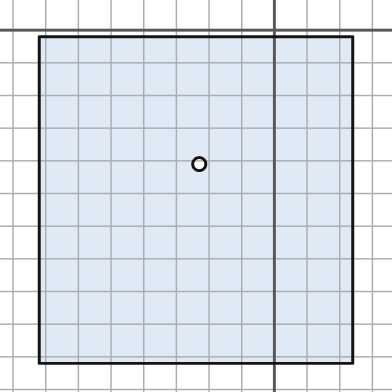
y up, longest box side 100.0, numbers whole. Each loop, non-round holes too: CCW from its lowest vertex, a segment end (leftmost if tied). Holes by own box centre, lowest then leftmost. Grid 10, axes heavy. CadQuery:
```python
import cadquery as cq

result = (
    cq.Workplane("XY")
    .moveTo(-72.0, -102.0)
    .lineTo(24.0, -102.0)
    .lineTo(24.0, -2.0)
    .lineTo(-72.0, -2.0)
    .close()
    .moveTo(-23.0, -41.0)
    .circle(2.0)
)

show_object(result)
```